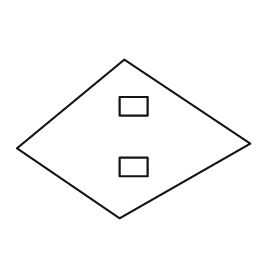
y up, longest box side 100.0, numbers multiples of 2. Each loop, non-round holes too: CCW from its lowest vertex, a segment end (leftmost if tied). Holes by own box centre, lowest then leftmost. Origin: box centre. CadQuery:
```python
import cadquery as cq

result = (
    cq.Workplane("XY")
    .moveTo(-6.0, -34.0)
    .lineTo(50.0, -2.0)
    .lineTo(-4.0, 34.0)
    .lineTo(-50.0, -4.0)
    .close()
    .moveTo(-6.0, -16.0)
    .lineTo(6.0, -16.0)
    .lineTo(6.0, -8.0)
    .lineTo(-6.0, -8.0)
    .close()
    .moveTo(-6.0, 10.0)
    .lineTo(6.0, 10.0)
    .lineTo(6.0, 18.0)
    .lineTo(-6.0, 18.0)
    .close()
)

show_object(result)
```